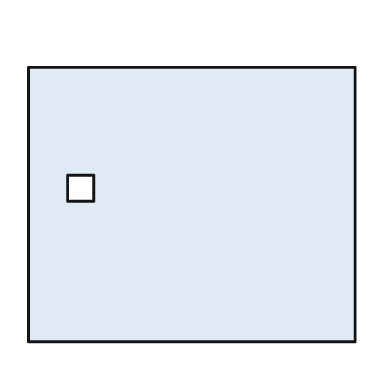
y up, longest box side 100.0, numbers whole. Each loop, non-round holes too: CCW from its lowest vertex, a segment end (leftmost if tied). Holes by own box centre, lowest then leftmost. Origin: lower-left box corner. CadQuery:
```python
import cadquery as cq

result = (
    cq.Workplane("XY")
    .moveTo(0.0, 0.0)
    .lineTo(100.0, 0.0)
    .lineTo(100.0, 84.0)
    .lineTo(0.0, 84.0)
    .close()
    .moveTo(12.0, 43.0)
    .lineTo(20.0, 43.0)
    .lineTo(20.0, 51.0)
    .lineTo(12.0, 51.0)
    .close()
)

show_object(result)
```